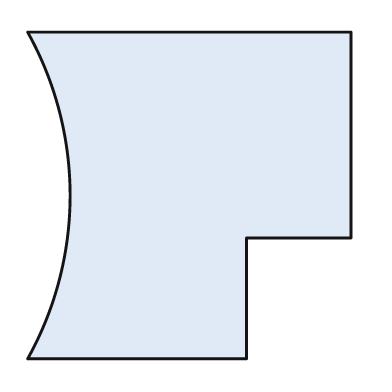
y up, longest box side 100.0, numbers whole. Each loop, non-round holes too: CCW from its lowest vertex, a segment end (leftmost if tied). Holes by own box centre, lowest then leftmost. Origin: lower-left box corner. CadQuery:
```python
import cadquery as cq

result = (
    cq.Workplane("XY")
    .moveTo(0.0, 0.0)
    .lineTo(67.0, 0.0)
    .lineTo(67.0, 37.0)
    .lineTo(99.0, 37.0)
    .lineTo(99.0, 100.0)
    .lineTo(0.0, 100.0)
    .threePointArc((13.0, 50.0), (0.0, 0.0))
    .close()
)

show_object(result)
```